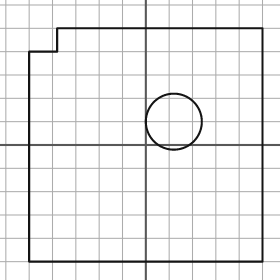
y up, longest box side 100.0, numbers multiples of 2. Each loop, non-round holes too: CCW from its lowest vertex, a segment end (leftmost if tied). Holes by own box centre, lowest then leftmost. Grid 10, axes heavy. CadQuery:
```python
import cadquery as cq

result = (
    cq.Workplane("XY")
    .moveTo(-50.0, -50.0)
    .lineTo(50.0, -50.0)
    .lineTo(50.0, 50.0)
    .lineTo(-38.0, 50.0)
    .lineTo(-38.0, 40.0)
    .lineTo(-50.0, 40.0)
    .close()
    .moveTo(12.0, 10.0)
    .circle(12.0)
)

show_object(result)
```